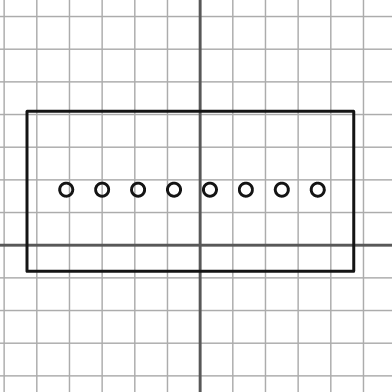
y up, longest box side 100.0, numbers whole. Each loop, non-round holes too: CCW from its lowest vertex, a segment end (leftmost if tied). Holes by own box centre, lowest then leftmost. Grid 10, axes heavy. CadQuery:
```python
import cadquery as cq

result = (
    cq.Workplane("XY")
    .moveTo(-53.0, -8.0)
    .lineTo(47.0, -8.0)
    .lineTo(47.0, 41.0)
    .lineTo(-53.0, 41.0)
    .close()
    .moveTo(-41.0, 17.0)
    .circle(2.0)
    .moveTo(-30.0, 17.0)
    .circle(2.0)
    .moveTo(-19.0, 17.0)
    .circle(2.0)
    .moveTo(-8.0, 17.0)
    .circle(2.0)
    .moveTo(3.0, 17.0)
    .circle(2.0)
    .moveTo(14.0, 17.0)
    .circle(2.0)
    .moveTo(25.0, 17.0)
    .circle(2.0)
    .moveTo(36.0, 17.0)
    .circle(2.0)
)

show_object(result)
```